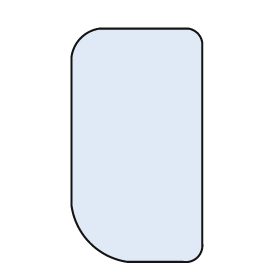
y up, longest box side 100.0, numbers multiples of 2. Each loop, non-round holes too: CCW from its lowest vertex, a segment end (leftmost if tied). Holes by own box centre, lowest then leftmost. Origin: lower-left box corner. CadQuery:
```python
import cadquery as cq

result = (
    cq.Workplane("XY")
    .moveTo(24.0, 0.0)
    .lineTo(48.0, 0.0)
    .threePointArc((54.0, 2.0), (56.0, 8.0))
    .lineTo(56.0, 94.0)
    .threePointArc((54.0, 98.0), (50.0, 100.0))
    .lineTo(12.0, 100.0)
    .threePointArc((4.0, 96.0), (0.0, 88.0))
    .lineTo(0.0, 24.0)
    .threePointArc((8.0, 8.0), (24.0, 0.0))
    .close()
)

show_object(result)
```